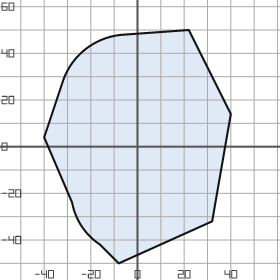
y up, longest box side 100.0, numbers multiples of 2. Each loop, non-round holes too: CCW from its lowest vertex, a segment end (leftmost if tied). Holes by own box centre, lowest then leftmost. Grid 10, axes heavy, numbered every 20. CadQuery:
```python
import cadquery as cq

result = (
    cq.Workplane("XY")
    .moveTo(-8.0, -50.0)
    .lineTo(32.0, -32.0)
    .lineTo(40.0, 14.0)
    .lineTo(22.0, 50.0)
    .lineTo(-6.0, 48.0)
    .threePointArc((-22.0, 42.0), (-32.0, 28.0))
    .lineTo(-40.0, 4.0)
    .lineTo(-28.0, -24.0)
    .threePointArc((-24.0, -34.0), (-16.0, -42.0))
    .close()
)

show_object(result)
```